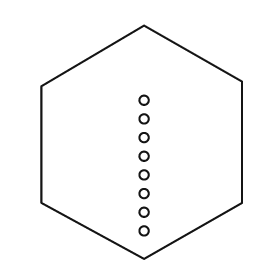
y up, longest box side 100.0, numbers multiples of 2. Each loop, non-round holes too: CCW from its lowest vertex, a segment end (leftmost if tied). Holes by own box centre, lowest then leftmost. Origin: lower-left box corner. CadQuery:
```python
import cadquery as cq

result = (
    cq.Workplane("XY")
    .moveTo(44.0, 0.0)
    .lineTo(86.0, 24.0)
    .lineTo(86.0, 76.0)
    .lineTo(44.0, 100.0)
    .lineTo(0.0, 74.0)
    .lineTo(0.0, 24.0)
    .close()
    .moveTo(44.0, 12.0)
    .circle(2.0)
    .moveTo(44.0, 20.0)
    .circle(2.0)
    .moveTo(44.0, 28.0)
    .circle(2.0)
    .moveTo(44.0, 36.0)
    .circle(2.0)
    .moveTo(44.0, 44.0)
    .circle(2.0)
    .moveTo(44.0, 52.0)
    .circle(2.0)
    .moveTo(44.0, 60.0)
    .circle(2.0)
    .moveTo(44.0, 68.0)
    .circle(2.0)
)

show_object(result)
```